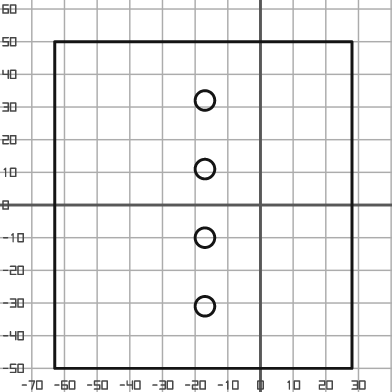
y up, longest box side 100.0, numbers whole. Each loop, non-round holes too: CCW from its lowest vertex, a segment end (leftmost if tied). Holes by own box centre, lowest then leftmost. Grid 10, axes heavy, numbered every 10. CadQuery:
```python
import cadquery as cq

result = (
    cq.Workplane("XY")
    .moveTo(-63.0, -50.0)
    .lineTo(28.0, -50.0)
    .lineTo(28.0, 50.0)
    .lineTo(-63.0, 50.0)
    .close()
    .moveTo(-17.0, -31.0)
    .circle(3.0)
    .moveTo(-17.0, -10.0)
    .circle(3.0)
    .moveTo(-17.0, 11.0)
    .circle(3.0)
    .moveTo(-17.0, 32.0)
    .circle(3.0)
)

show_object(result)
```